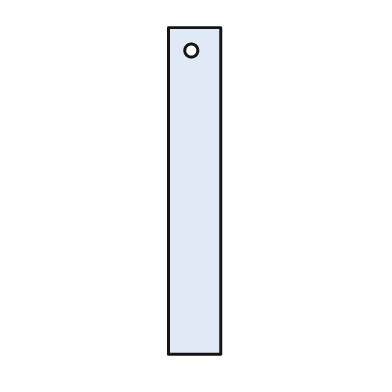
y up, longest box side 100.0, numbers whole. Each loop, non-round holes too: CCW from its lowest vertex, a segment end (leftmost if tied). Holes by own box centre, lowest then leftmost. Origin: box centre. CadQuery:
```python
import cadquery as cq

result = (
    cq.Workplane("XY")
    .moveTo(-8.0, -50.0)
    .lineTo(8.0, -50.0)
    .lineTo(8.0, 50.0)
    .lineTo(-8.0, 50.0)
    .close()
    .moveTo(-1.0, 43.0)
    .circle(2.0)
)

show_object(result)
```